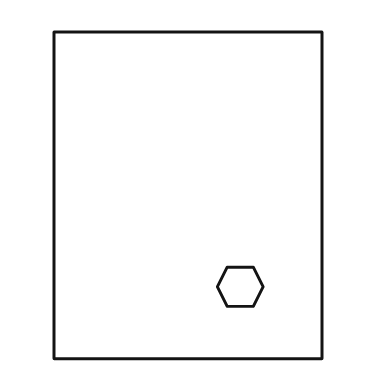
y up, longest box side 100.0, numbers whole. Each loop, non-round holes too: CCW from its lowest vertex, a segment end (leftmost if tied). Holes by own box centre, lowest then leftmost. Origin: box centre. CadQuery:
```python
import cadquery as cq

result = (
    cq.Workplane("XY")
    .moveTo(-41.0, -50.0)
    .lineTo(41.0, -50.0)
    .lineTo(41.0, 50.0)
    .lineTo(-41.0, 50.0)
    .close()
    .moveTo(12.0, -34.0)
    .lineTo(20.0, -34.0)
    .lineTo(23.0, -28.0)
    .lineTo(20.0, -22.0)
    .lineTo(12.0, -22.0)
    .lineTo(9.0, -28.0)
    .close()
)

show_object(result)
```